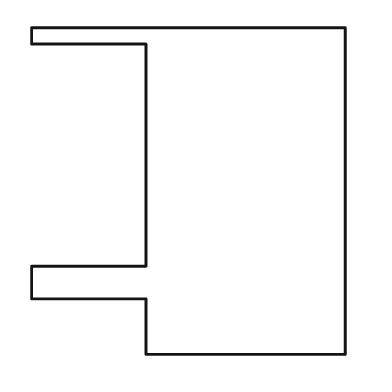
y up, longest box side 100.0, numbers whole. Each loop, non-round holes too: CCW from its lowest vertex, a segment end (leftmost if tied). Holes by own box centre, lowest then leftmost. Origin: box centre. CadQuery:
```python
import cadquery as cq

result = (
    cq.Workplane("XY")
    .moveTo(-13.0, -50.0)
    .lineTo(48.0, -50.0)
    .lineTo(48.0, 50.0)
    .lineTo(-48.0, 50.0)
    .lineTo(-48.0, 45.0)
    .lineTo(-13.0, 45.0)
    .lineTo(-13.0, -23.0)
    .lineTo(-48.0, -23.0)
    .lineTo(-48.0, -33.0)
    .lineTo(-13.0, -33.0)
    .close()
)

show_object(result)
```